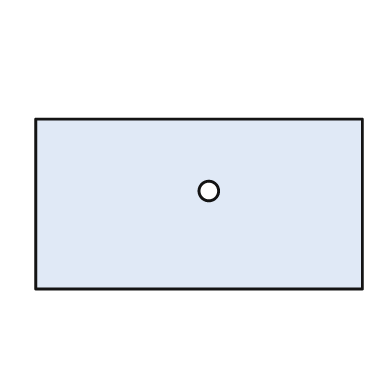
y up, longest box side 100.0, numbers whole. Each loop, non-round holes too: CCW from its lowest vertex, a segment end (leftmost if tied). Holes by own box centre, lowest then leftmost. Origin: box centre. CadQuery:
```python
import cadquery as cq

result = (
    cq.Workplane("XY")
    .moveTo(-50.0, -26.0)
    .lineTo(50.0, -26.0)
    .lineTo(50.0, 26.0)
    .lineTo(-50.0, 26.0)
    .close()
    .moveTo(3.0, 4.0)
    .circle(3.0)
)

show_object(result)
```